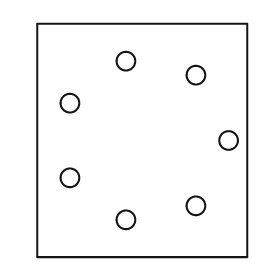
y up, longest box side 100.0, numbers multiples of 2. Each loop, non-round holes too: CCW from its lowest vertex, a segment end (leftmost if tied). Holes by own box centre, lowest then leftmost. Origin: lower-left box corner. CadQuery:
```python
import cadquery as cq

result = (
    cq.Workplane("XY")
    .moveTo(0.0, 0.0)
    .lineTo(90.0, 0.0)
    .lineTo(90.0, 100.0)
    .lineTo(0.0, 100.0)
    .close()
    .moveTo(38.0, 16.0)
    .circle(4.0)
    .moveTo(68.0, 22.0)
    .circle(4.0)
    .moveTo(14.0, 34.0)
    .circle(4.0)
    .moveTo(82.0, 50.0)
    .circle(4.0)
    .moveTo(14.0, 66.0)
    .circle(4.0)
    .moveTo(68.0, 78.0)
    .circle(4.0)
    .moveTo(38.0, 84.0)
    .circle(4.0)
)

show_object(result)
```